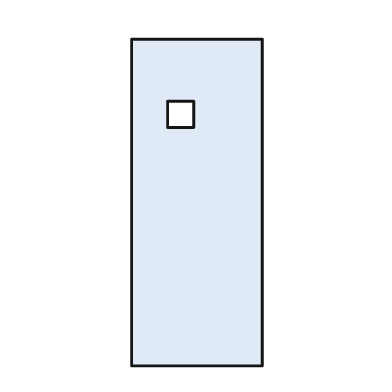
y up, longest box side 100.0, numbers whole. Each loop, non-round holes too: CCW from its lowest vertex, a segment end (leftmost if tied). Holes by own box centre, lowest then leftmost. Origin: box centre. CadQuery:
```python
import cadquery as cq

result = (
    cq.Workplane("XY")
    .moveTo(-20.0, -50.0)
    .lineTo(20.0, -50.0)
    .lineTo(20.0, 50.0)
    .lineTo(-20.0, 50.0)
    .close()
    .moveTo(-9.0, 23.0)
    .lineTo(-1.0, 23.0)
    .lineTo(-1.0, 31.0)
    .lineTo(-9.0, 31.0)
    .close()
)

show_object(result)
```